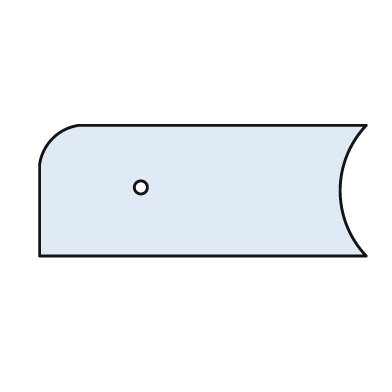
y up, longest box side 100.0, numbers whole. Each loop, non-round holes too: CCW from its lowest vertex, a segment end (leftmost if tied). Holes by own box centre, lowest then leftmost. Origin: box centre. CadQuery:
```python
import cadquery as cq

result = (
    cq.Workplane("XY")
    .moveTo(-50.0, -20.0)
    .lineTo(50.0, -20.0)
    .threePointArc((42.0, 0.0), (50.0, 20.0))
    .lineTo(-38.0, 20.0)
    .threePointArc((-46.0, 16.0), (-50.0, 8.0))
    .close()
    .moveTo(-19.0, 1.0)
    .circle(2.0)
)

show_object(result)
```